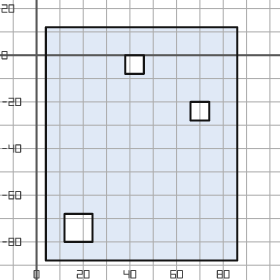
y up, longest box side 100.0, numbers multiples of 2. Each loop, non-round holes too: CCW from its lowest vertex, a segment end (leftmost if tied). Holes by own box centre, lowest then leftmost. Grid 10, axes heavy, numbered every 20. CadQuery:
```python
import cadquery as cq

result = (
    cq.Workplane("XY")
    .moveTo(4.0, -88.0)
    .lineTo(86.0, -88.0)
    .lineTo(86.0, 12.0)
    .lineTo(4.0, 12.0)
    .close()
    .moveTo(12.0, -80.0)
    .lineTo(24.0, -80.0)
    .lineTo(24.0, -68.0)
    .lineTo(12.0, -68.0)
    .close()
    .moveTo(66.0, -28.0)
    .lineTo(74.0, -28.0)
    .lineTo(74.0, -20.0)
    .lineTo(66.0, -20.0)
    .close()
    .moveTo(38.0, -8.0)
    .lineTo(46.0, -8.0)
    .lineTo(46.0, 0.0)
    .lineTo(38.0, 0.0)
    .close()
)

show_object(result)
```